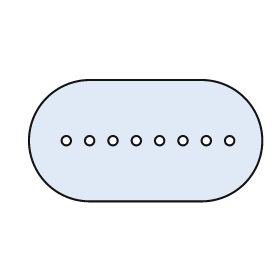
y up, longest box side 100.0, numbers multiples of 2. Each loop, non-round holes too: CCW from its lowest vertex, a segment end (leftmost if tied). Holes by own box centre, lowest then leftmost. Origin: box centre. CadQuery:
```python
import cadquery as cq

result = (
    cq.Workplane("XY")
    .moveTo(-24.0, -26.0)
    .lineTo(24.0, -26.0)
    .threePointArc((50.0, 0.0), (24.0, 26.0))
    .lineTo(-24.0, 26.0)
    .threePointArc((-50.0, 0.0), (-24.0, -26.0))
    .close()
    .moveTo(-34.0, 0.0)
    .circle(2.0)
    .moveTo(-24.0, 0.0)
    .circle(2.0)
    .moveTo(-14.0, 0.0)
    .circle(2.0)
    .moveTo(-4.0, 0.0)
    .circle(2.0)
    .moveTo(6.0, 0.0)
    .circle(2.0)
    .moveTo(16.0, 0.0)
    .circle(2.0)
    .moveTo(26.0, 0.0)
    .circle(2.0)
    .moveTo(36.0, 0.0)
    .circle(2.0)
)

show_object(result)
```